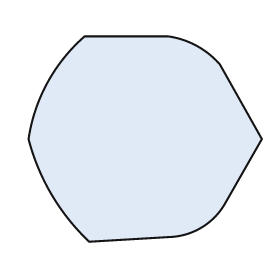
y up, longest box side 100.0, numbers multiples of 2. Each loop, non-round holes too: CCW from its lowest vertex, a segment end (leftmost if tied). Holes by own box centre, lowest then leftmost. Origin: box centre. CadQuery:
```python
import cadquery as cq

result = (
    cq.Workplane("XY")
    .moveTo(-24.0, -44.0)
    .lineTo(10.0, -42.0)
    .threePointArc((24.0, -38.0), (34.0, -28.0))
    .lineTo(50.0, 0.0)
    .lineTo(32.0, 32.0)
    .threePointArc((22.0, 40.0), (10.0, 44.0))
    .lineTo(-26.0, 44.0)
    .threePointArc((-42.0, 24.0), (-50.0, 0.0))
    .threePointArc((-40.0, -24.0), (-24.0, -44.0))
    .close()
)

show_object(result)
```